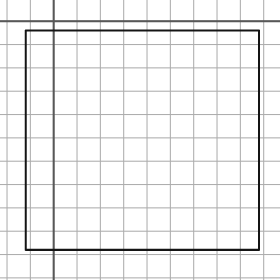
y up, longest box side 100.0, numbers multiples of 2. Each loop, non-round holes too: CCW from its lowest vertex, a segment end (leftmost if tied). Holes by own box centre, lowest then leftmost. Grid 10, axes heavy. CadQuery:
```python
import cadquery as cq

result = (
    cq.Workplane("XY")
    .moveTo(-12.0, -98.0)
    .lineTo(88.0, -98.0)
    .lineTo(88.0, -4.0)
    .lineTo(-12.0, -4.0)
    .close()
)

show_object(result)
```